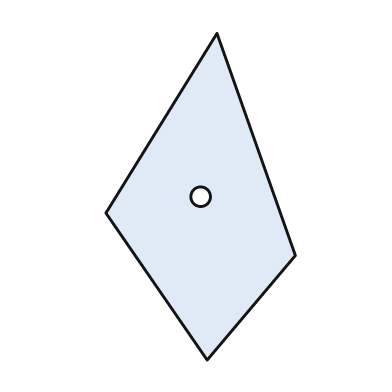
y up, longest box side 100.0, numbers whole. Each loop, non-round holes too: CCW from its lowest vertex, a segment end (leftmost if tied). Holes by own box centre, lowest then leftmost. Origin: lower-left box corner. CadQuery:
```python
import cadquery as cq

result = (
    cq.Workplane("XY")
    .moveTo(31.0, 0.0)
    .lineTo(58.0, 32.0)
    .lineTo(34.0, 100.0)
    .lineTo(0.0, 45.0)
    .close()
    .moveTo(29.0, 50.0)
    .circle(3.0)
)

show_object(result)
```